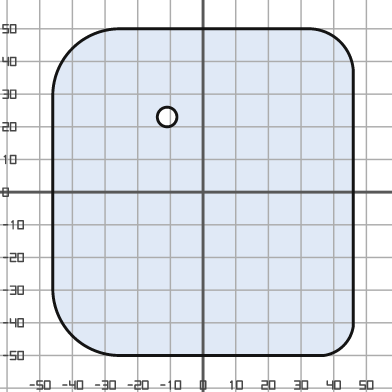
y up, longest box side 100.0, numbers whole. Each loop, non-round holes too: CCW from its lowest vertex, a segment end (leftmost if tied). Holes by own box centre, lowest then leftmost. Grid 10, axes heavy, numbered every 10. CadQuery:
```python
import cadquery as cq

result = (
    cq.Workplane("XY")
    .moveTo(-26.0, -50.0)
    .lineTo(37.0, -50.0)
    .threePointArc((43.0, -47.0), (46.0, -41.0))
    .lineTo(46.0, 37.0)
    .threePointArc((42.0, 46.0), (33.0, 50.0))
    .lineTo(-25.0, 50.0)
    .threePointArc((-40.0, 44.0), (-46.0, 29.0))
    .lineTo(-46.0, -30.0)
    .threePointArc((-40.0, -44.0), (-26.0, -50.0))
    .close()
    .moveTo(-11.0, 23.0)
    .circle(3.0)
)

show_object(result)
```